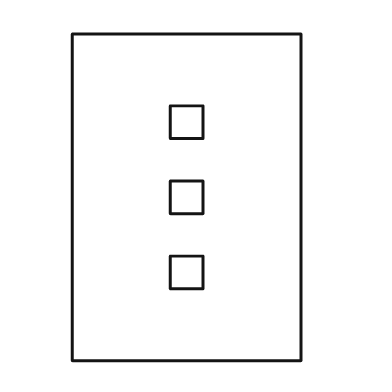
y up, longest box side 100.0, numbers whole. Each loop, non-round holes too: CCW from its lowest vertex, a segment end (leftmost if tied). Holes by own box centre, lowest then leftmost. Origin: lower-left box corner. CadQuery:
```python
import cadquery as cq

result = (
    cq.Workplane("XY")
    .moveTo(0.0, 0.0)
    .lineTo(70.0, 0.0)
    .lineTo(70.0, 100.0)
    .lineTo(0.0, 100.0)
    .close()
    .moveTo(30.0, 22.0)
    .lineTo(40.0, 22.0)
    .lineTo(40.0, 32.0)
    .lineTo(30.0, 32.0)
    .close()
    .moveTo(30.0, 45.0)
    .lineTo(40.0, 45.0)
    .lineTo(40.0, 55.0)
    .lineTo(30.0, 55.0)
    .close()
    .moveTo(30.0, 68.0)
    .lineTo(40.0, 68.0)
    .lineTo(40.0, 78.0)
    .lineTo(30.0, 78.0)
    .close()
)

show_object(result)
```